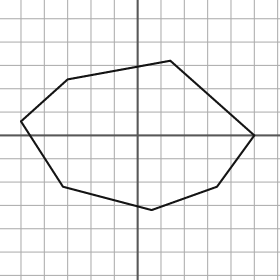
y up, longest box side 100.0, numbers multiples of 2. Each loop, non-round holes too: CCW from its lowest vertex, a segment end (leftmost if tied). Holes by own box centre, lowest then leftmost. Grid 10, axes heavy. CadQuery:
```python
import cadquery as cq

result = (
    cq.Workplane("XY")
    .moveTo(6.0, -32.0)
    .lineTo(34.0, -22.0)
    .lineTo(50.0, 0.0)
    .lineTo(14.0, 32.0)
    .lineTo(-30.0, 24.0)
    .lineTo(-50.0, 6.0)
    .lineTo(-32.0, -22.0)
    .close()
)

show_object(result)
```